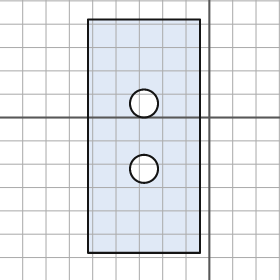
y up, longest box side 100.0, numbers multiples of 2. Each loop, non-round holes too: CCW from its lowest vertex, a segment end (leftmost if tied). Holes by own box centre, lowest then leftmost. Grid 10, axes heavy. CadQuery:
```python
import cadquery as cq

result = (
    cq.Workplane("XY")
    .moveTo(-52.0, -58.0)
    .lineTo(-4.0, -58.0)
    .lineTo(-4.0, 42.0)
    .lineTo(-52.0, 42.0)
    .close()
    .moveTo(-28.0, -22.0)
    .circle(6.0)
    .moveTo(-28.0, 6.0)
    .circle(6.0)
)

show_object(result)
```